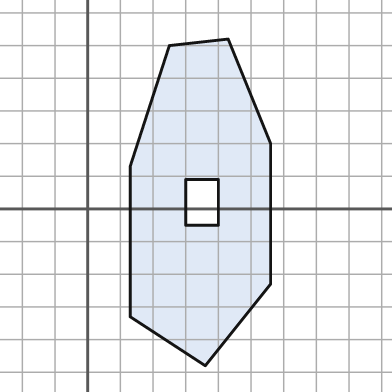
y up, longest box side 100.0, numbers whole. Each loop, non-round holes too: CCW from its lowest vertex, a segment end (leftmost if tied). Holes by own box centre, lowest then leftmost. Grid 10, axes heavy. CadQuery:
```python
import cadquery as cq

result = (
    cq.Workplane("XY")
    .moveTo(36.0, -48.0)
    .lineTo(56.0, -23.0)
    .lineTo(56.0, 20.0)
    .lineTo(43.0, 52.0)
    .lineTo(25.0, 50.0)
    .lineTo(13.0, 13.0)
    .lineTo(13.0, -33.0)
    .close()
    .moveTo(30.0, -5.0)
    .lineTo(40.0, -5.0)
    .lineTo(40.0, 9.0)
    .lineTo(30.0, 9.0)
    .close()
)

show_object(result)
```